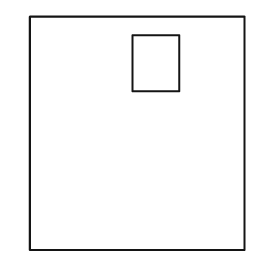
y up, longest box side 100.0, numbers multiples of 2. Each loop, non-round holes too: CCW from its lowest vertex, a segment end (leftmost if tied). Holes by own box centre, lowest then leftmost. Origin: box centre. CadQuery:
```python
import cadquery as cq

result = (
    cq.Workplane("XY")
    .moveTo(-46.0, -50.0)
    .lineTo(46.0, -50.0)
    .lineTo(46.0, 50.0)
    .lineTo(-46.0, 50.0)
    .close()
    .moveTo(-2.0, 18.0)
    .lineTo(18.0, 18.0)
    .lineTo(18.0, 42.0)
    .lineTo(-2.0, 42.0)
    .close()
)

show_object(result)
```